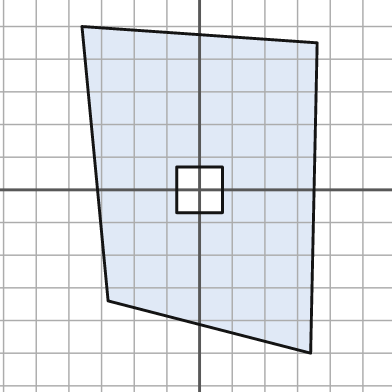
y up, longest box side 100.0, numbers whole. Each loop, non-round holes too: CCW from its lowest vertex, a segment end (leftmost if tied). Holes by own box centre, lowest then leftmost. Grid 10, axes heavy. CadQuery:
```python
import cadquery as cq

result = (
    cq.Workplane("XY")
    .moveTo(34.0, -50.0)
    .lineTo(36.0, 45.0)
    .lineTo(-36.0, 50.0)
    .lineTo(-28.0, -34.0)
    .close()
    .moveTo(-7.0, -7.0)
    .lineTo(7.0, -7.0)
    .lineTo(7.0, 7.0)
    .lineTo(-7.0, 7.0)
    .close()
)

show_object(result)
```